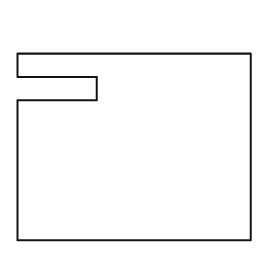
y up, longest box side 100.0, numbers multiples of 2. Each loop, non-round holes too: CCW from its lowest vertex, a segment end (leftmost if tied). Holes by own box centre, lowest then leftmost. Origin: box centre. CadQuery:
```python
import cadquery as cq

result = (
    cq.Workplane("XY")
    .moveTo(-50.0, -40.0)
    .lineTo(50.0, -40.0)
    .lineTo(50.0, 40.0)
    .lineTo(-50.0, 40.0)
    .lineTo(-50.0, 30.0)
    .lineTo(-16.0, 30.0)
    .lineTo(-16.0, 20.0)
    .lineTo(-50.0, 20.0)
    .close()
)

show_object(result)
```